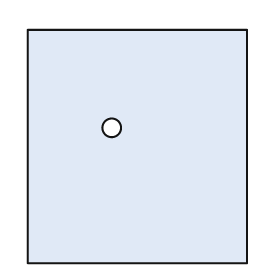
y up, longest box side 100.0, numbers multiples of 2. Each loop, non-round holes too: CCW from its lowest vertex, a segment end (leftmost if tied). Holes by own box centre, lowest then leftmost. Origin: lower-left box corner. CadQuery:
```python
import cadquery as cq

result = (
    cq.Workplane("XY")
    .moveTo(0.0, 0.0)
    .lineTo(94.0, 0.0)
    .lineTo(94.0, 100.0)
    .lineTo(0.0, 100.0)
    .close()
    .moveTo(36.0, 58.0)
    .circle(4.0)
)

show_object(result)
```